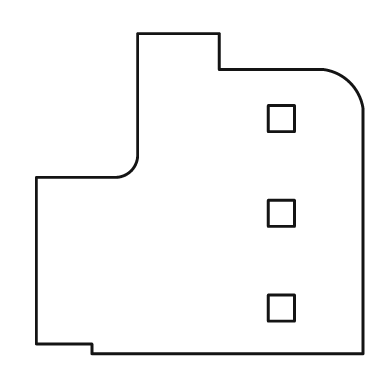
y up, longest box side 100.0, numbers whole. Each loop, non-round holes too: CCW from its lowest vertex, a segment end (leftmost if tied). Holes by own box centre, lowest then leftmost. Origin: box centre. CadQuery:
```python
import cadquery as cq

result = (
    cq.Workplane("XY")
    .moveTo(-33.0, -49.0)
    .lineTo(50.0, -49.0)
    .lineTo(50.0, 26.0)
    .threePointArc((46.0, 34.0), (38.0, 38.0))
    .lineTo(6.0, 38.0)
    .lineTo(6.0, 49.0)
    .lineTo(-19.0, 49.0)
    .lineTo(-19.0, 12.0)
    .threePointArc((-21.0, 7.0), (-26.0, 5.0))
    .lineTo(-50.0, 5.0)
    .lineTo(-50.0, -46.0)
    .lineTo(-33.0, -46.0)
    .close()
    .moveTo(21.0, -39.0)
    .lineTo(29.0, -39.0)
    .lineTo(29.0, -31.0)
    .lineTo(21.0, -31.0)
    .close()
    .moveTo(21.0, -10.0)
    .lineTo(29.0, -10.0)
    .lineTo(29.0, -2.0)
    .lineTo(21.0, -2.0)
    .close()
    .moveTo(21.0, 19.0)
    .lineTo(29.0, 19.0)
    .lineTo(29.0, 27.0)
    .lineTo(21.0, 27.0)
    .close()
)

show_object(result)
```